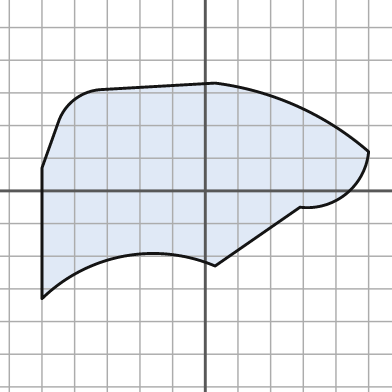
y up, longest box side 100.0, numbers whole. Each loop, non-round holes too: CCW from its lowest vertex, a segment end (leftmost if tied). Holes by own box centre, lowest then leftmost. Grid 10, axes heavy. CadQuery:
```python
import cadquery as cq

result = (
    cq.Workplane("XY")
    .moveTo(-50.0, -33.0)
    .threePointArc((-25.0, -20.0), (3.0, -23.0))
    .lineTo(29.0, -5.0)
    .threePointArc((43.0, -1.0), (50.0, 12.0))
    .threePointArc((28.0, 26.0), (3.0, 33.0))
    .lineTo(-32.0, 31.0)
    .threePointArc((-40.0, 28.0), (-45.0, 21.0))
    .lineTo(-50.0, 7.0)
    .close()
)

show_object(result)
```